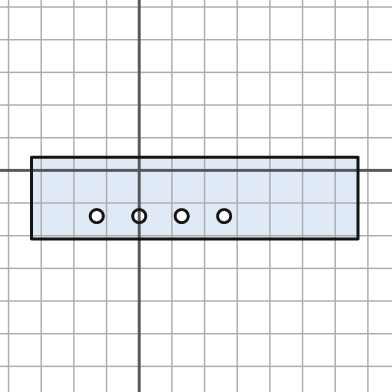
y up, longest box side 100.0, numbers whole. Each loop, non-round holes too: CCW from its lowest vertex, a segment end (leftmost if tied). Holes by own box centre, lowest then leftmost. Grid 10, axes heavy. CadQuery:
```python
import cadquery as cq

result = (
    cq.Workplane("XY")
    .moveTo(-33.0, -21.0)
    .lineTo(67.0, -21.0)
    .lineTo(67.0, 4.0)
    .lineTo(-33.0, 4.0)
    .close()
    .moveTo(-13.0, -14.0)
    .circle(2.0)
    .moveTo(0.0, -14.0)
    .circle(2.0)
    .moveTo(13.0, -14.0)
    .circle(2.0)
    .moveTo(26.0, -14.0)
    .circle(2.0)
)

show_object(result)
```